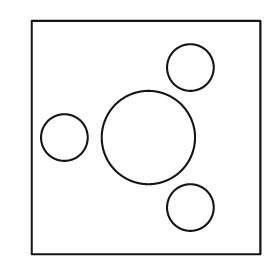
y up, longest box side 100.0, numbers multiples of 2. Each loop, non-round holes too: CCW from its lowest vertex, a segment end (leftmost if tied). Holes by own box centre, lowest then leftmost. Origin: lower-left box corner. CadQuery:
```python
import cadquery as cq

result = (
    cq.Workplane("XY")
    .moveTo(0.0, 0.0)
    .lineTo(98.0, 0.0)
    .lineTo(98.0, 100.0)
    .lineTo(0.0, 100.0)
    .close()
    .moveTo(68.0, 20.0)
    .circle(10.0)
    .moveTo(14.0, 50.0)
    .circle(10.0)
    .moveTo(50.0, 50.0)
    .circle(20.0)
    .moveTo(68.0, 80.0)
    .circle(10.0)
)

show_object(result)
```